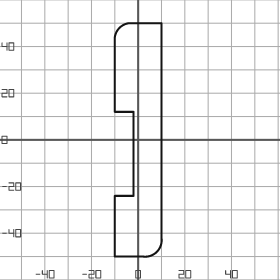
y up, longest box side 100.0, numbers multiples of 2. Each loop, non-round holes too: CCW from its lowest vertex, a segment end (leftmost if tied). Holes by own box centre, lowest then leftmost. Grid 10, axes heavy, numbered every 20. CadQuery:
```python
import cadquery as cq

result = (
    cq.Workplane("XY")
    .moveTo(-10.0, -50.0)
    .lineTo(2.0, -50.0)
    .threePointArc((8.0, -48.0), (10.0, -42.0))
    .lineTo(10.0, 50.0)
    .lineTo(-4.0, 50.0)
    .threePointArc((-8.0, 48.0), (-10.0, 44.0))
    .lineTo(-10.0, 12.0)
    .lineTo(-2.0, 12.0)
    .lineTo(-2.0, -24.0)
    .lineTo(-10.0, -24.0)
    .close()
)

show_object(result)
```